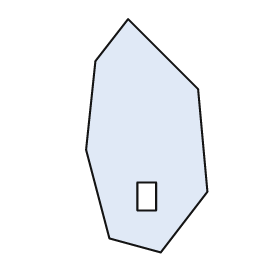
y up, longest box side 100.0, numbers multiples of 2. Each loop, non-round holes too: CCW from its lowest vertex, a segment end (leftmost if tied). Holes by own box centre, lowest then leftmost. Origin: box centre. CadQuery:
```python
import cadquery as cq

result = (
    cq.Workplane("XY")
    .moveTo(6.0, -50.0)
    .lineTo(26.0, -24.0)
    .lineTo(22.0, 20.0)
    .lineTo(-8.0, 50.0)
    .lineTo(-22.0, 32.0)
    .lineTo(-26.0, -6.0)
    .lineTo(-16.0, -44.0)
    .close()
    .moveTo(-4.0, -32.0)
    .lineTo(4.0, -32.0)
    .lineTo(4.0, -20.0)
    .lineTo(-4.0, -20.0)
    .close()
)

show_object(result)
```